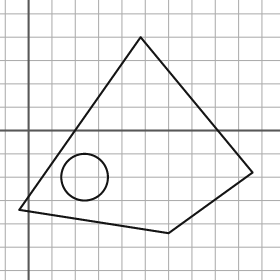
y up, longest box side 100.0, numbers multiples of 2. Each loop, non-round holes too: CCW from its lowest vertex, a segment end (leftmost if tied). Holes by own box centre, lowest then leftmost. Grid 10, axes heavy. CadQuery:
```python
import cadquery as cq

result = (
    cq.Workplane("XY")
    .moveTo(60.0, -44.0)
    .lineTo(96.0, -18.0)
    .lineTo(48.0, 40.0)
    .lineTo(-4.0, -34.0)
    .close()
    .moveTo(24.0, -20.0)
    .circle(10.0)
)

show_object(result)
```